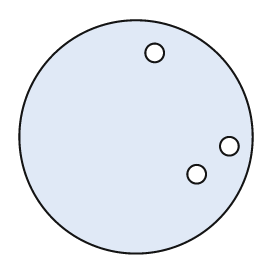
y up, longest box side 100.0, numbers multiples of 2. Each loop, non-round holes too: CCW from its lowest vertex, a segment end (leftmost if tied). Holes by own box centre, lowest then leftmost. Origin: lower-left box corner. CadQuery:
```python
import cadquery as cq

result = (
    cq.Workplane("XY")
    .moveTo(50.0, 50.0)
    .circle(50.0)
    .moveTo(76.0, 34.0)
    .circle(4.0)
    .moveTo(90.0, 46.0)
    .circle(4.0)
    .moveTo(58.0, 86.0)
    .circle(4.0)
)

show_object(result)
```